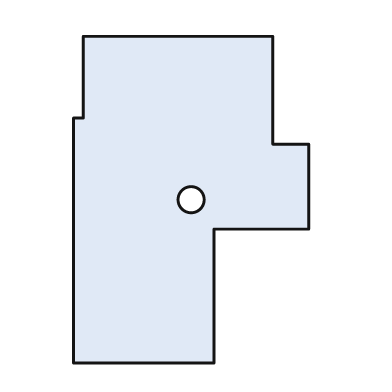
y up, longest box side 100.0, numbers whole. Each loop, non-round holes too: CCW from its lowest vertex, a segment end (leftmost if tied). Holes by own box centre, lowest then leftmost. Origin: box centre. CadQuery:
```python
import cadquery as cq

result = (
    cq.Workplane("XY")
    .moveTo(-36.0, -50.0)
    .lineTo(7.0, -50.0)
    .lineTo(7.0, -9.0)
    .lineTo(36.0, -9.0)
    .lineTo(36.0, 17.0)
    .lineTo(25.0, 17.0)
    .lineTo(25.0, 50.0)
    .lineTo(-33.0, 50.0)
    .lineTo(-33.0, 25.0)
    .lineTo(-36.0, 25.0)
    .close()
    .moveTo(0.0, 0.0)
    .circle(4.0)
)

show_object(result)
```